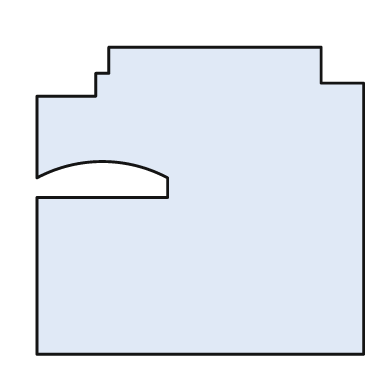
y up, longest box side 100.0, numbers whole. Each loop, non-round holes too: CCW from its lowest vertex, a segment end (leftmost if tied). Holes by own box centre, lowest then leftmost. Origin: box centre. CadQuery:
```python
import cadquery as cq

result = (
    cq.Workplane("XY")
    .moveTo(-50.0, -47.0)
    .lineTo(50.0, -47.0)
    .lineTo(50.0, 36.0)
    .lineTo(37.0, 36.0)
    .lineTo(37.0, 47.0)
    .lineTo(-28.0, 47.0)
    .lineTo(-28.0, 39.0)
    .lineTo(-32.0, 39.0)
    .lineTo(-32.0, 32.0)
    .lineTo(-50.0, 32.0)
    .lineTo(-50.0, 7.0)
    .threePointArc((-30.0, 12.0), (-10.0, 7.0))
    .lineTo(-10.0, 1.0)
    .lineTo(-50.0, 1.0)
    .close()
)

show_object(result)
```